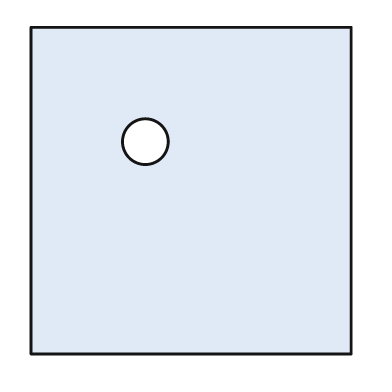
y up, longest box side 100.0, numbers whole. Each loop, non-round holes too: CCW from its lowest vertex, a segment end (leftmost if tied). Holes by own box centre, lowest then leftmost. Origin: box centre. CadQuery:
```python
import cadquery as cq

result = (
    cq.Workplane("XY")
    .moveTo(-49.0, -50.0)
    .lineTo(49.0, -50.0)
    .lineTo(49.0, 50.0)
    .lineTo(-49.0, 50.0)
    .close()
    .moveTo(-14.0, 15.0)
    .circle(7.0)
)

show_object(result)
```